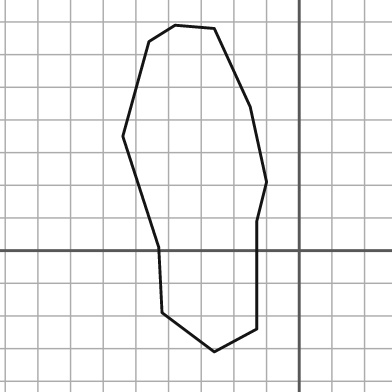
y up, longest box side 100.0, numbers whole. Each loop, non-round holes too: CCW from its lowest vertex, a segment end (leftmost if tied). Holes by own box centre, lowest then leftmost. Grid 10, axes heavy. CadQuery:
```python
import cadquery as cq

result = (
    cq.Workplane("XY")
    .moveTo(-26.0, -31.0)
    .lineTo(-13.0, -24.0)
    .lineTo(-13.0, 9.0)
    .lineTo(-10.0, 21.0)
    .lineTo(-15.0, 44.0)
    .lineTo(-26.0, 68.0)
    .lineTo(-38.0, 69.0)
    .lineTo(-46.0, 64.0)
    .lineTo(-54.0, 35.0)
    .lineTo(-43.0, 1.0)
    .lineTo(-42.0, -19.0)
    .close()
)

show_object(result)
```